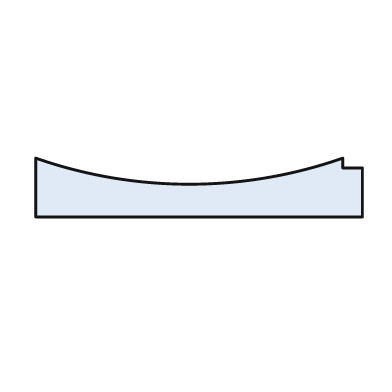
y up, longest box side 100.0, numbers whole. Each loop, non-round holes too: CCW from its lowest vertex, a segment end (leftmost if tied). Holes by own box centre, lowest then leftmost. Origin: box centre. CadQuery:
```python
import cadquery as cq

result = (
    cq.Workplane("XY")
    .moveTo(-50.0, -9.0)
    .lineTo(50.0, -9.0)
    .lineTo(50.0, 6.0)
    .lineTo(44.0, 6.0)
    .lineTo(44.0, 9.0)
    .threePointArc((-3.0, 1.0), (-50.0, 9.0))
    .close()
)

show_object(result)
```